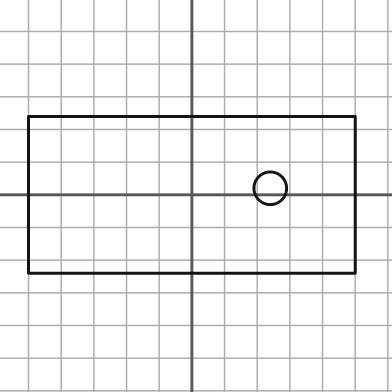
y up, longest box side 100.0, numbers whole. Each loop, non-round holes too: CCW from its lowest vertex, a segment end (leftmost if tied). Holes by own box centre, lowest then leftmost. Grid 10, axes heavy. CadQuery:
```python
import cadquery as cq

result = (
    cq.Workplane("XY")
    .moveTo(-50.0, -24.0)
    .lineTo(50.0, -24.0)
    .lineTo(50.0, 24.0)
    .lineTo(-50.0, 24.0)
    .close()
    .moveTo(24.0, 2.0)
    .circle(5.0)
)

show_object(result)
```